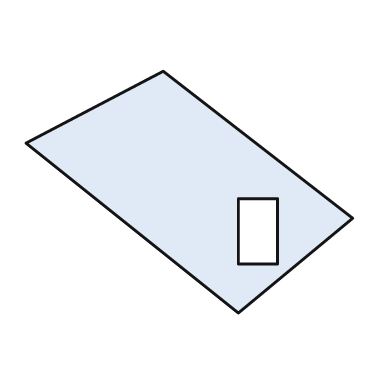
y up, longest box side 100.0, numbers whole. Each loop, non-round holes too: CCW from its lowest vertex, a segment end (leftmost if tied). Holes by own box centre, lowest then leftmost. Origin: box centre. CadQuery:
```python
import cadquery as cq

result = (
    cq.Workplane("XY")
    .moveTo(15.0, -37.0)
    .lineTo(50.0, -8.0)
    .lineTo(-8.0, 37.0)
    .lineTo(-50.0, 15.0)
    .close()
    .moveTo(15.0, -22.0)
    .lineTo(27.0, -22.0)
    .lineTo(27.0, -2.0)
    .lineTo(15.0, -2.0)
    .close()
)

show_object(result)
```